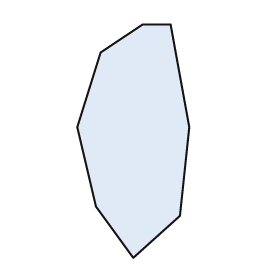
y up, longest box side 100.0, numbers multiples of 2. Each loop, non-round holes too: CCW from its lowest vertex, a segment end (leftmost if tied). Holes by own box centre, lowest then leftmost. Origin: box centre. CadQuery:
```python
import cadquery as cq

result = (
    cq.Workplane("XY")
    .moveTo(0.0, -50.0)
    .lineTo(20.0, -32.0)
    .lineTo(24.0, 6.0)
    .lineTo(16.0, 50.0)
    .lineTo(4.0, 50.0)
    .lineTo(-14.0, 38.0)
    .lineTo(-24.0, 6.0)
    .lineTo(-16.0, -28.0)
    .close()
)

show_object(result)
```